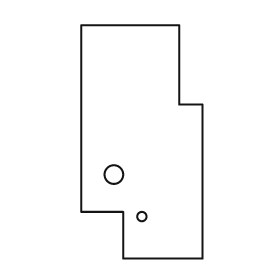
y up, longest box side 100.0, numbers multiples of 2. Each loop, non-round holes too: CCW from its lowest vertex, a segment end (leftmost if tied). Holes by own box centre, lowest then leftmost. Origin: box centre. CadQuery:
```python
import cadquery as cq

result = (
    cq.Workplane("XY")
    .moveTo(-8.0, -50.0)
    .lineTo(26.0, -50.0)
    .lineTo(26.0, 16.0)
    .lineTo(16.0, 16.0)
    .lineTo(16.0, 50.0)
    .lineTo(-26.0, 50.0)
    .lineTo(-26.0, -30.0)
    .lineTo(-8.0, -30.0)
    .close()
    .moveTo(0.0, -32.0)
    .circle(2.0)
    .moveTo(-12.0, -14.0)
    .circle(4.0)
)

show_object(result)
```